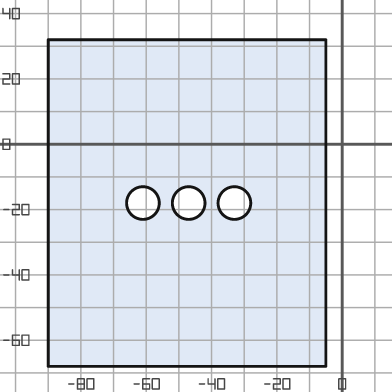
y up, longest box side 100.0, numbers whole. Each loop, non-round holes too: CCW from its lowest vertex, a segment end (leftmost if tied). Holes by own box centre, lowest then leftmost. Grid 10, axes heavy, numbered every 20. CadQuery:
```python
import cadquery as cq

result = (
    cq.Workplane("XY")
    .moveTo(-90.0, -68.0)
    .lineTo(-5.0, -68.0)
    .lineTo(-5.0, 32.0)
    .lineTo(-90.0, 32.0)
    .close()
    .moveTo(-61.0, -18.0)
    .circle(5.0)
    .moveTo(-47.0, -18.0)
    .circle(5.0)
    .moveTo(-33.0, -18.0)
    .circle(5.0)
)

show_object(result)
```